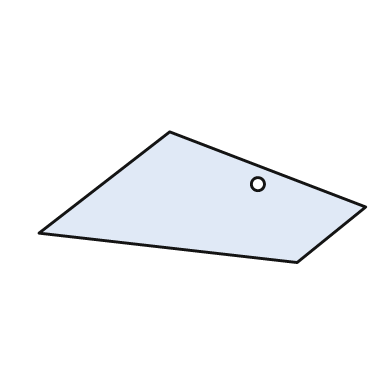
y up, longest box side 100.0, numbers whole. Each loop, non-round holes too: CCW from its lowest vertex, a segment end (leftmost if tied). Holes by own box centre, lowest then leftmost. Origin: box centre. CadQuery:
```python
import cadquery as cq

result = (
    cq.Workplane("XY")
    .moveTo(29.0, -20.0)
    .lineTo(50.0, -3.0)
    .lineTo(-10.0, 20.0)
    .lineTo(-50.0, -11.0)
    .close()
    .moveTo(17.0, 4.0)
    .circle(2.0)
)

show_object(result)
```